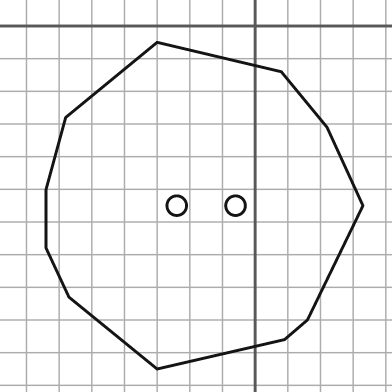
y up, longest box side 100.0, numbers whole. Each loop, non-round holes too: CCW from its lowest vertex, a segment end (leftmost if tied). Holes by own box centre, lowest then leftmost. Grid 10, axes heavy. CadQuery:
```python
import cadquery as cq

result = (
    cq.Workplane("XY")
    .moveTo(-30.0, -105.0)
    .lineTo(9.0, -96.0)
    .lineTo(16.0, -90.0)
    .lineTo(33.0, -55.0)
    .lineTo(22.0, -31.0)
    .lineTo(8.0, -14.0)
    .lineTo(-30.0, -5.0)
    .lineTo(-58.0, -28.0)
    .lineTo(-64.0, -50.0)
    .lineTo(-64.0, -68.0)
    .lineTo(-57.0, -83.0)
    .close()
    .moveTo(-24.0, -55.0)
    .circle(3.0)
    .moveTo(-6.0, -55.0)
    .circle(3.0)
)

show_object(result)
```